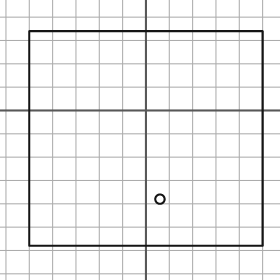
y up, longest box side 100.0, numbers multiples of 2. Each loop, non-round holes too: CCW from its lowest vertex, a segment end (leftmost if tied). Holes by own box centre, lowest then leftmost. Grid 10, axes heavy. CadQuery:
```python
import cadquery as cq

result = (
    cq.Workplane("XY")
    .moveTo(-50.0, -58.0)
    .lineTo(50.0, -58.0)
    .lineTo(50.0, 34.0)
    .lineTo(-50.0, 34.0)
    .close()
    .moveTo(6.0, -38.0)
    .circle(2.0)
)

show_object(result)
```